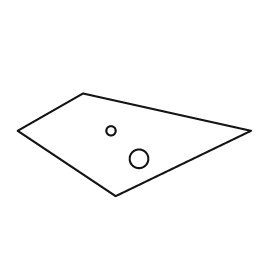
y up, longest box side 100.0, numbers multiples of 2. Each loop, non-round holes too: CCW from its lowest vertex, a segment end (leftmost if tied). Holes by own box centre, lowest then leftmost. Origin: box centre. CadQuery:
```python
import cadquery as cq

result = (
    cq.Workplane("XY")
    .moveTo(-8.0, -22.0)
    .lineTo(50.0, 6.0)
    .lineTo(-22.0, 22.0)
    .lineTo(-50.0, 6.0)
    .close()
    .moveTo(2.0, -6.0)
    .circle(4.0)
    .moveTo(-10.0, 6.0)
    .circle(2.0)
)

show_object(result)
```